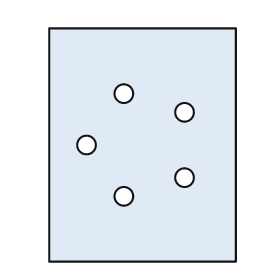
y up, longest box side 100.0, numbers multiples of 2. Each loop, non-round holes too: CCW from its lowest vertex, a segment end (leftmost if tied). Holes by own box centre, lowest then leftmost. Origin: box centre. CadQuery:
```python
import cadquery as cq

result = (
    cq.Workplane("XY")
    .moveTo(-40.0, -50.0)
    .lineTo(40.0, -50.0)
    .lineTo(40.0, 50.0)
    .lineTo(-40.0, 50.0)
    .close()
    .moveTo(-8.0, -22.0)
    .circle(4.0)
    .moveTo(18.0, -14.0)
    .circle(4.0)
    .moveTo(-24.0, 0.0)
    .circle(4.0)
    .moveTo(18.0, 14.0)
    .circle(4.0)
    .moveTo(-8.0, 22.0)
    .circle(4.0)
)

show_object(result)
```